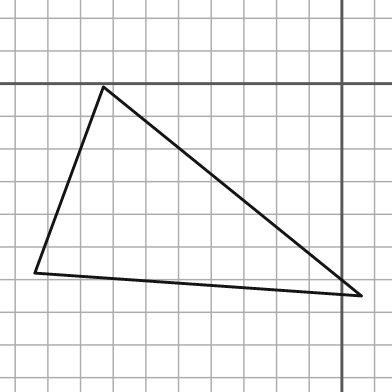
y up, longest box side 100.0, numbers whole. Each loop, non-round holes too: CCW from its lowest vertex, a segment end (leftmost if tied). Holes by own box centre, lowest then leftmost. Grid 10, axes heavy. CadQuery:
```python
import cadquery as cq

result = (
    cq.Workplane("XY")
    .moveTo(6.0, -65.0)
    .lineTo(-73.0, -1.0)
    .lineTo(-94.0, -58.0)
    .close()
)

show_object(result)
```